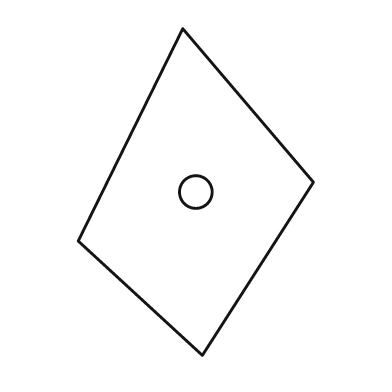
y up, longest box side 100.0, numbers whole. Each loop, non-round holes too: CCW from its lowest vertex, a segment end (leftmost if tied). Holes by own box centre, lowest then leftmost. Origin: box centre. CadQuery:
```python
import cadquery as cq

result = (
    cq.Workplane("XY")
    .moveTo(2.0, -50.0)
    .lineTo(36.0, 3.0)
    .lineTo(-4.0, 50.0)
    .lineTo(-36.0, -15.0)
    .close()
    .moveTo(0.0, 0.0)
    .circle(5.0)
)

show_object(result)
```